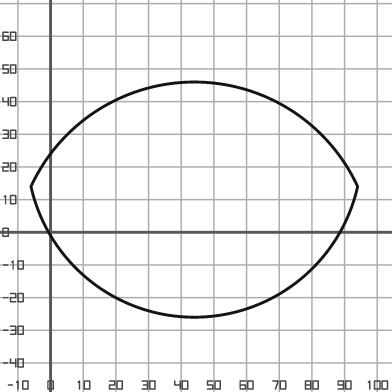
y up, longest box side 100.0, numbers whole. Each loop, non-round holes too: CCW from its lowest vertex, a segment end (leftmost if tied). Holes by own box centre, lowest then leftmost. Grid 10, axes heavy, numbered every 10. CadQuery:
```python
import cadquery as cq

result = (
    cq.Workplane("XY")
    .moveTo(-6.0, 14.0)
    .threePointArc((44.0, -26.0), (94.0, 14.0))
    .threePointArc((44.0, 46.0), (-6.0, 14.0))
    .close()
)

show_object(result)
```